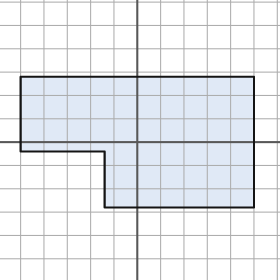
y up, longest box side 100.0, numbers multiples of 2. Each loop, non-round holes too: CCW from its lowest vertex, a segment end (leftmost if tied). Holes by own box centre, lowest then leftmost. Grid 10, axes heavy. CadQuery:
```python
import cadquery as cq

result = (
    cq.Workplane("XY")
    .moveTo(-14.0, -28.0)
    .lineTo(50.0, -28.0)
    .lineTo(50.0, 28.0)
    .lineTo(-50.0, 28.0)
    .lineTo(-50.0, -4.0)
    .lineTo(-14.0, -4.0)
    .close()
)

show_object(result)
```